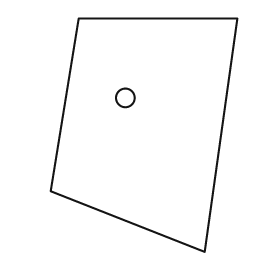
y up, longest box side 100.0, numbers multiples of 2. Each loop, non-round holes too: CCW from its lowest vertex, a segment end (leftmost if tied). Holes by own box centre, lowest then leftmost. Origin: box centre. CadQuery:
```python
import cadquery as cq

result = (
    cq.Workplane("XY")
    .moveTo(26.0, -50.0)
    .lineTo(40.0, 50.0)
    .lineTo(-28.0, 50.0)
    .lineTo(-40.0, -24.0)
    .close()
    .moveTo(-8.0, 16.0)
    .circle(4.0)
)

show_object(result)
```